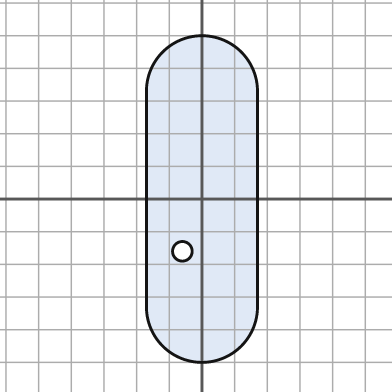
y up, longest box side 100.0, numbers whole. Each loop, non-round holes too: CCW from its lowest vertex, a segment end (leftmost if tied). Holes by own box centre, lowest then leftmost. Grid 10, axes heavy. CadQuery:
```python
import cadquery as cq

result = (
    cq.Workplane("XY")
    .moveTo(-17.0, -33.0)
    .threePointArc((0.0, -50.0), (17.0, -33.0))
    .lineTo(17.0, 33.0)
    .threePointArc((0.0, 50.0), (-17.0, 33.0))
    .close()
    .moveTo(-6.0, -16.0)
    .circle(3.0)
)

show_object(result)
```